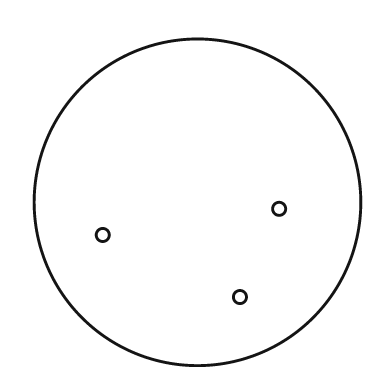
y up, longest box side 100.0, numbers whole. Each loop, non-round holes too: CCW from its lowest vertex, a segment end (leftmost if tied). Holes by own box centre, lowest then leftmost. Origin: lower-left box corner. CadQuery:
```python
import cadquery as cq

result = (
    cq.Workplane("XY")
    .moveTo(50.0, 50.0)
    .circle(50.0)
    .moveTo(63.0, 21.0)
    .circle(2.0)
    .moveTo(21.0, 40.0)
    .circle(2.0)
    .moveTo(75.0, 48.0)
    .circle(2.0)
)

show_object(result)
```